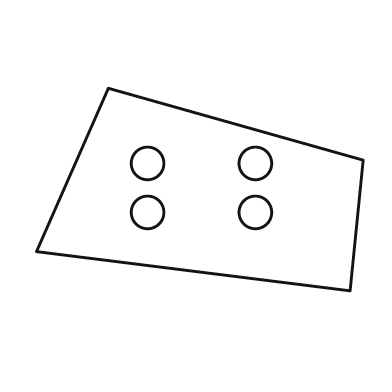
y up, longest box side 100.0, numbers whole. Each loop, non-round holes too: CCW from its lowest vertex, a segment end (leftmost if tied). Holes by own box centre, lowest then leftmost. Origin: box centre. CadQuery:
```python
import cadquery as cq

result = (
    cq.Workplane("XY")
    .moveTo(46.0, -31.0)
    .lineTo(50.0, 9.0)
    .lineTo(-28.0, 31.0)
    .lineTo(-50.0, -19.0)
    .close()
    .moveTo(-16.0, -7.0)
    .circle(5.0)
    .moveTo(17.0, -7.0)
    .circle(5.0)
    .moveTo(-16.0, 8.0)
    .circle(5.0)
    .moveTo(17.0, 8.0)
    .circle(5.0)
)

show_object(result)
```